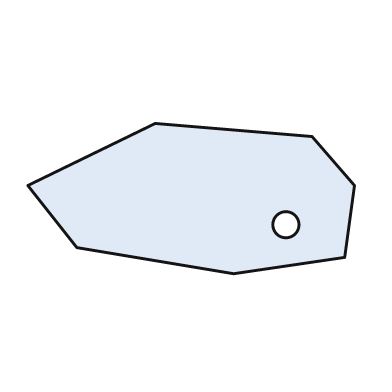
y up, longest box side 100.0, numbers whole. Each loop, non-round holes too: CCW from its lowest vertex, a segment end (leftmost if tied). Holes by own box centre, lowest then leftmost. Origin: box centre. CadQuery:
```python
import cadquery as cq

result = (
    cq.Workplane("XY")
    .moveTo(13.0, -23.0)
    .lineTo(47.0, -18.0)
    .lineTo(50.0, 4.0)
    .lineTo(37.0, 19.0)
    .lineTo(-11.0, 23.0)
    .lineTo(-50.0, 4.0)
    .lineTo(-35.0, -15.0)
    .close()
    .moveTo(29.0, -8.0)
    .circle(4.0)
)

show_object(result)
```